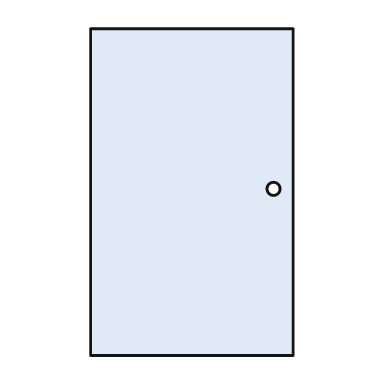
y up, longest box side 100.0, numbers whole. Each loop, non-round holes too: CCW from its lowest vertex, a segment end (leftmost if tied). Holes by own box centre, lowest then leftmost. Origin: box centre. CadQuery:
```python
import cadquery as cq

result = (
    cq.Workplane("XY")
    .moveTo(-31.0, -50.0)
    .lineTo(31.0, -50.0)
    .lineTo(31.0, 50.0)
    .lineTo(-31.0, 50.0)
    .close()
    .moveTo(25.0, 1.0)
    .circle(2.0)
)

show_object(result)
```